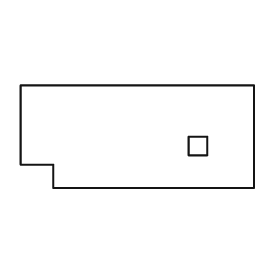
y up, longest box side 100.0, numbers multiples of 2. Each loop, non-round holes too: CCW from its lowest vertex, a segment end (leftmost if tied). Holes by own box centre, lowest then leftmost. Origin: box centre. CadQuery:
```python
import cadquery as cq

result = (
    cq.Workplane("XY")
    .moveTo(-36.0, -22.0)
    .lineTo(50.0, -22.0)
    .lineTo(50.0, 22.0)
    .lineTo(-50.0, 22.0)
    .lineTo(-50.0, -12.0)
    .lineTo(-36.0, -12.0)
    .close()
    .moveTo(22.0, -8.0)
    .lineTo(30.0, -8.0)
    .lineTo(30.0, 0.0)
    .lineTo(22.0, 0.0)
    .close()
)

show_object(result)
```